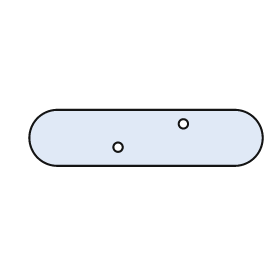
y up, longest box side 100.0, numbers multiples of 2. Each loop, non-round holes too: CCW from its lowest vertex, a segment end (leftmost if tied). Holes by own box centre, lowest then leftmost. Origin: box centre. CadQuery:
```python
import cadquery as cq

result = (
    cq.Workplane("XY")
    .moveTo(-38.0, -12.0)
    .lineTo(38.0, -12.0)
    .threePointArc((50.0, 0.0), (38.0, 12.0))
    .lineTo(-38.0, 12.0)
    .threePointArc((-50.0, 0.0), (-38.0, -12.0))
    .close()
    .moveTo(-12.0, -4.0)
    .circle(2.0)
    .moveTo(16.0, 6.0)
    .circle(2.0)
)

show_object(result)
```